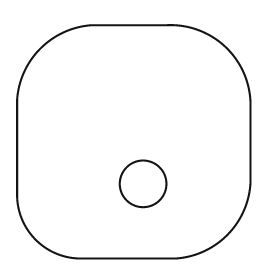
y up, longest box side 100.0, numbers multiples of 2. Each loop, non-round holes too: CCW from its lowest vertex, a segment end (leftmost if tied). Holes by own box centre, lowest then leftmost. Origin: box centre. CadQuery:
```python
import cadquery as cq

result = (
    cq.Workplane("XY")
    .moveTo(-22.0, -50.0)
    .lineTo(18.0, -50.0)
    .threePointArc((40.0, -40.0), (50.0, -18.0))
    .lineTo(50.0, 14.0)
    .threePointArc((40.0, 40.0), (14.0, 50.0))
    .lineTo(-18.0, 50.0)
    .threePointArc((-40.0, 40.0), (-50.0, 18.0))
    .lineTo(-50.0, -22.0)
    .threePointArc((-42.0, -42.0), (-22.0, -50.0))
    .close()
    .moveTo(4.0, -18.0)
    .circle(10.0)
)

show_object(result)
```